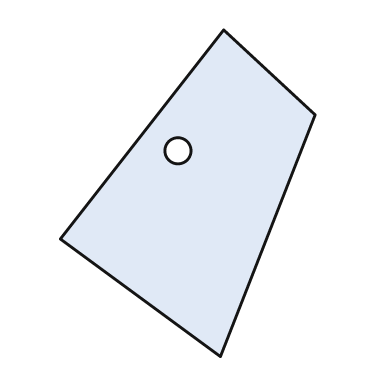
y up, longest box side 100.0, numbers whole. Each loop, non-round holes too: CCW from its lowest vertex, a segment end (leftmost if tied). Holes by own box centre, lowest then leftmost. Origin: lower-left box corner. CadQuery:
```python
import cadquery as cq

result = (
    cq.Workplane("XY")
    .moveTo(49.0, 0.0)
    .lineTo(78.0, 74.0)
    .lineTo(50.0, 100.0)
    .lineTo(0.0, 36.0)
    .close()
    .moveTo(36.0, 63.0)
    .circle(4.0)
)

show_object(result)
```